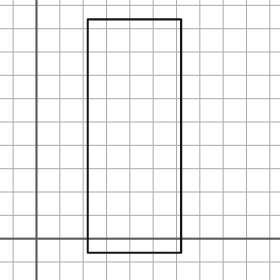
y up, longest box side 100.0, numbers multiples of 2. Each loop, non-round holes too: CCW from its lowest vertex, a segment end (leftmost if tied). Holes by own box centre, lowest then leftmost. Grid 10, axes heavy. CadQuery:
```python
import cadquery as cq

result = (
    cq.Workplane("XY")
    .moveTo(22.0, -6.0)
    .lineTo(62.0, -6.0)
    .lineTo(62.0, 94.0)
    .lineTo(22.0, 94.0)
    .close()
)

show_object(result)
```